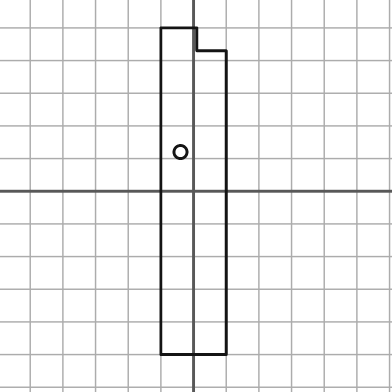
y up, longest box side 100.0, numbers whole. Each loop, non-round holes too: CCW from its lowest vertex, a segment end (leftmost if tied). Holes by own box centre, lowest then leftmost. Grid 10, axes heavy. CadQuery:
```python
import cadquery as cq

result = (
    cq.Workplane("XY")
    .moveTo(-10.0, -50.0)
    .lineTo(10.0, -50.0)
    .lineTo(10.0, 43.0)
    .lineTo(1.0, 43.0)
    .lineTo(1.0, 50.0)
    .lineTo(-10.0, 50.0)
    .close()
    .moveTo(-4.0, 12.0)
    .circle(2.0)
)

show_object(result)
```